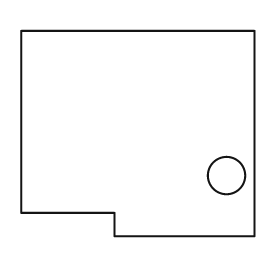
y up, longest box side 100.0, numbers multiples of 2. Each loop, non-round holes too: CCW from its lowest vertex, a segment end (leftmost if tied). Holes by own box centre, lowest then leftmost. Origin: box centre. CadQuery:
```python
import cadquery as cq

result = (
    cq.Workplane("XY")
    .moveTo(-10.0, -44.0)
    .lineTo(50.0, -44.0)
    .lineTo(50.0, 44.0)
    .lineTo(-50.0, 44.0)
    .lineTo(-50.0, -34.0)
    .lineTo(-10.0, -34.0)
    .close()
    .moveTo(38.0, -18.0)
    .circle(8.0)
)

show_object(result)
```